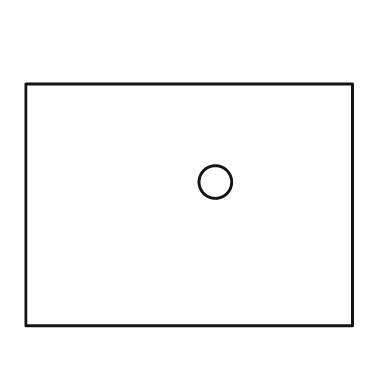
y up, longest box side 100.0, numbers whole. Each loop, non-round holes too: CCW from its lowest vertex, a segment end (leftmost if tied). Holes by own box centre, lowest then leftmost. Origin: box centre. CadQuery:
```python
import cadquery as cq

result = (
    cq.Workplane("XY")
    .moveTo(-50.0, -37.0)
    .lineTo(50.0, -37.0)
    .lineTo(50.0, 37.0)
    .lineTo(-50.0, 37.0)
    .close()
    .moveTo(8.0, 7.0)
    .circle(5.0)
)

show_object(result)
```